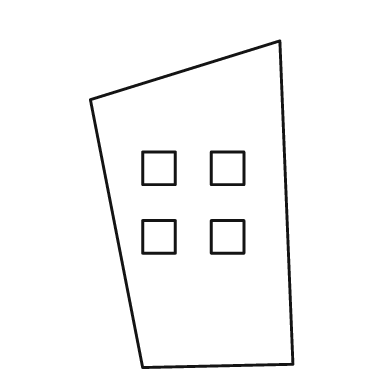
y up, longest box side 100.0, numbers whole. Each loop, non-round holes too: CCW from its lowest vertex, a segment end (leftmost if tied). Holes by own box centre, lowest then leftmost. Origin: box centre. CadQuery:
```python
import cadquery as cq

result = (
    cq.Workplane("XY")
    .moveTo(-15.0, -50.0)
    .lineTo(31.0, -49.0)
    .lineTo(27.0, 50.0)
    .lineTo(-31.0, 32.0)
    .close()
    .moveTo(-15.0, -15.0)
    .lineTo(-5.0, -15.0)
    .lineTo(-5.0, -5.0)
    .lineTo(-15.0, -5.0)
    .close()
    .moveTo(6.0, -15.0)
    .lineTo(16.0, -15.0)
    .lineTo(16.0, -5.0)
    .lineTo(6.0, -5.0)
    .close()
    .moveTo(-15.0, 6.0)
    .lineTo(-5.0, 6.0)
    .lineTo(-5.0, 16.0)
    .lineTo(-15.0, 16.0)
    .close()
    .moveTo(6.0, 6.0)
    .lineTo(16.0, 6.0)
    .lineTo(16.0, 16.0)
    .lineTo(6.0, 16.0)
    .close()
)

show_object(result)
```